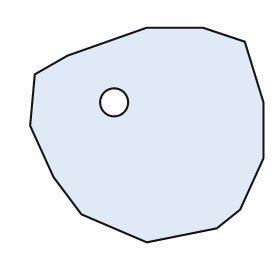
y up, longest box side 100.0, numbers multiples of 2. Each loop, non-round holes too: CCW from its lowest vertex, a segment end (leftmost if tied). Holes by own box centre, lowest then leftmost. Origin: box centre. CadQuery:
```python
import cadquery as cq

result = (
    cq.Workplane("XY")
    .moveTo(0.0, -46.0)
    .lineTo(30.0, -40.0)
    .lineTo(40.0, -32.0)
    .lineTo(50.0, -10.0)
    .lineTo(50.0, 14.0)
    .lineTo(42.0, 40.0)
    .lineTo(24.0, 46.0)
    .lineTo(0.0, 46.0)
    .lineTo(-34.0, 34.0)
    .lineTo(-48.0, 26.0)
    .lineTo(-50.0, 4.0)
    .lineTo(-40.0, -18.0)
    .lineTo(-28.0, -34.0)
    .close()
    .moveTo(-14.0, 14.0)
    .circle(6.0)
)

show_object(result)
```